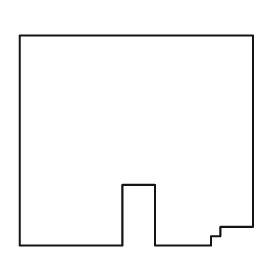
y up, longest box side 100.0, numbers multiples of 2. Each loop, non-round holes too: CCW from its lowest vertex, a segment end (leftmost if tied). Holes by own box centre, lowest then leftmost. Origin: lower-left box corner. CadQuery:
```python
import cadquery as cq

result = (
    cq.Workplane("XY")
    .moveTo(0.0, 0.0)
    .lineTo(44.0, 0.0)
    .lineTo(44.0, 26.0)
    .lineTo(58.0, 26.0)
    .lineTo(58.0, 0.0)
    .lineTo(82.0, 0.0)
    .lineTo(82.0, 4.0)
    .lineTo(86.0, 4.0)
    .lineTo(86.0, 8.0)
    .lineTo(100.0, 8.0)
    .lineTo(100.0, 90.0)
    .lineTo(0.0, 90.0)
    .close()
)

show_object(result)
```